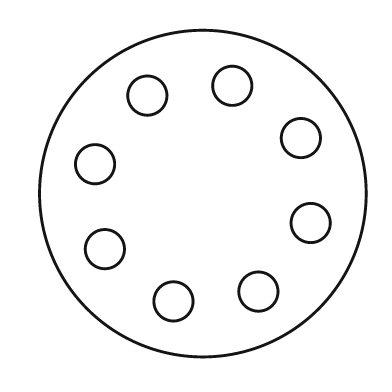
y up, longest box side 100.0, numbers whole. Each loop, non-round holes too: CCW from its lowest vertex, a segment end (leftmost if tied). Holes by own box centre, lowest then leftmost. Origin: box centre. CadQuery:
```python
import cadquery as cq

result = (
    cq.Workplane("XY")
    .moveTo(0.0, 0.0)
    .circle(50.0)
    .moveTo(-9.0, -33.0)
    .circle(6.0)
    .moveTo(17.0, -30.0)
    .circle(6.0)
    .moveTo(-30.0, -17.0)
    .circle(6.0)
    .moveTo(33.0, -9.0)
    .circle(6.0)
    .moveTo(-33.0, 9.0)
    .circle(6.0)
    .moveTo(30.0, 17.0)
    .circle(6.0)
    .moveTo(-17.0, 30.0)
    .circle(6.0)
    .moveTo(9.0, 33.0)
    .circle(6.0)
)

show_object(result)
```